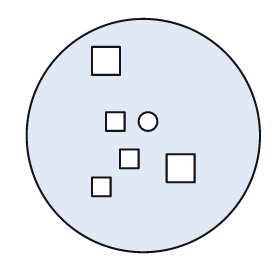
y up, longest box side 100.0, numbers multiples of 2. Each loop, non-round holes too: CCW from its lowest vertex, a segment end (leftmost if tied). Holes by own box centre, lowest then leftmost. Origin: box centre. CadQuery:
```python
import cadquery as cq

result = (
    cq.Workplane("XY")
    .moveTo(0.0, 0.0)
    .circle(50.0)
    .moveTo(-22.0, -26.0)
    .lineTo(-14.0, -26.0)
    .lineTo(-14.0, -18.0)
    .lineTo(-22.0, -18.0)
    .close()
    .moveTo(10.0, -20.0)
    .lineTo(22.0, -20.0)
    .lineTo(22.0, -8.0)
    .lineTo(10.0, -8.0)
    .close()
    .moveTo(-10.0, -14.0)
    .lineTo(-2.0, -14.0)
    .lineTo(-2.0, -6.0)
    .lineTo(-10.0, -6.0)
    .close()
    .moveTo(-16.0, 2.0)
    .lineTo(-8.0, 2.0)
    .lineTo(-8.0, 10.0)
    .lineTo(-16.0, 10.0)
    .close()
    .moveTo(2.0, 6.0)
    .circle(4.0)
    .moveTo(-22.0, 26.0)
    .lineTo(-10.0, 26.0)
    .lineTo(-10.0, 38.0)
    .lineTo(-22.0, 38.0)
    .close()
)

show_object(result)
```